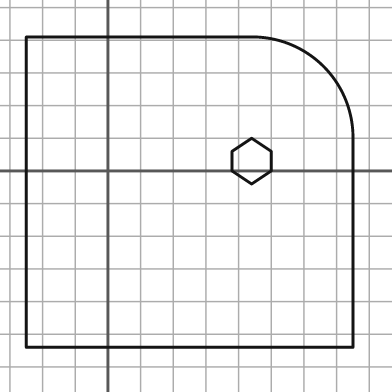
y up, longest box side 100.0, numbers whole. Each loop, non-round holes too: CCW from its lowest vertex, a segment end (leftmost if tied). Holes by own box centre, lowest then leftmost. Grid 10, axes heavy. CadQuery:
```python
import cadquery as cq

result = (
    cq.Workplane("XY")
    .moveTo(-25.0, -54.0)
    .lineTo(75.0, -54.0)
    .lineTo(75.0, 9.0)
    .threePointArc((66.0, 32.0), (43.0, 41.0))
    .lineTo(-25.0, 41.0)
    .close()
    .moveTo(44.0, -4.0)
    .lineTo(50.0, 0.0)
    .lineTo(50.0, 6.0)
    .lineTo(44.0, 10.0)
    .lineTo(38.0, 6.0)
    .lineTo(38.0, 0.0)
    .close()
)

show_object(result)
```